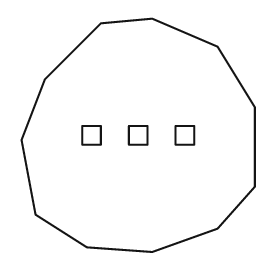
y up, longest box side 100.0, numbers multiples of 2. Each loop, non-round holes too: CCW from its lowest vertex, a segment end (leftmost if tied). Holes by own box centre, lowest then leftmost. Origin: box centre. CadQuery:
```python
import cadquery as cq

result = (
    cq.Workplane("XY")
    .moveTo(6.0, -50.0)
    .lineTo(34.0, -40.0)
    .lineTo(50.0, -22.0)
    .lineTo(50.0, 12.0)
    .lineTo(34.0, 38.0)
    .lineTo(6.0, 50.0)
    .lineTo(-16.0, 48.0)
    .lineTo(-40.0, 24.0)
    .lineTo(-50.0, -2.0)
    .lineTo(-44.0, -34.0)
    .lineTo(-22.0, -48.0)
    .close()
    .moveTo(-24.0, -4.0)
    .lineTo(-16.0, -4.0)
    .lineTo(-16.0, 4.0)
    .lineTo(-24.0, 4.0)
    .close()
    .moveTo(-4.0, -4.0)
    .lineTo(4.0, -4.0)
    .lineTo(4.0, 4.0)
    .lineTo(-4.0, 4.0)
    .close()
    .moveTo(16.0, -4.0)
    .lineTo(24.0, -4.0)
    .lineTo(24.0, 4.0)
    .lineTo(16.0, 4.0)
    .close()
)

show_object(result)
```